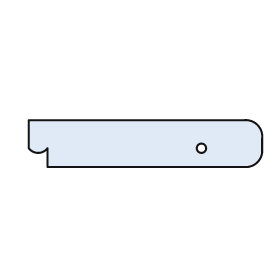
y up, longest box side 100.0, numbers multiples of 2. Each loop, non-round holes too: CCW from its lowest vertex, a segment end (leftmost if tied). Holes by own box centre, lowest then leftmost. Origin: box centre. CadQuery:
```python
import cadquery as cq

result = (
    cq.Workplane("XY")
    .moveTo(-42.0, -10.0)
    .lineTo(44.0, -10.0)
    .threePointArc((48.0, -8.0), (50.0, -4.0))
    .lineTo(50.0, 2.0)
    .threePointArc((48.0, 8.0), (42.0, 10.0))
    .lineTo(-50.0, 10.0)
    .lineTo(-50.0, -2.0)
    .threePointArc((-46.0, -4.0), (-42.0, -2.0))
    .close()
    .moveTo(24.0, -2.0)
    .circle(2.0)
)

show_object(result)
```